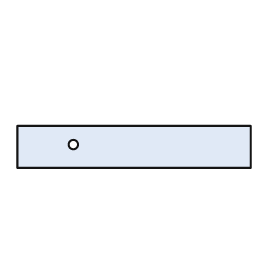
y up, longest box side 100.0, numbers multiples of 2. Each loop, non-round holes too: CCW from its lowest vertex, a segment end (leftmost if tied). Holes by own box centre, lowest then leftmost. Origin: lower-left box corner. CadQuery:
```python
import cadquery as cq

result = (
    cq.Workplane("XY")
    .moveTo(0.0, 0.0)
    .lineTo(100.0, 0.0)
    .lineTo(100.0, 18.0)
    .lineTo(0.0, 18.0)
    .close()
    .moveTo(24.0, 10.0)
    .circle(2.0)
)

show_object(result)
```